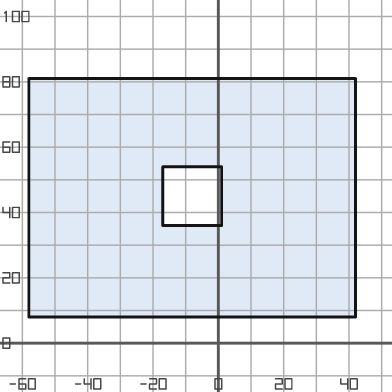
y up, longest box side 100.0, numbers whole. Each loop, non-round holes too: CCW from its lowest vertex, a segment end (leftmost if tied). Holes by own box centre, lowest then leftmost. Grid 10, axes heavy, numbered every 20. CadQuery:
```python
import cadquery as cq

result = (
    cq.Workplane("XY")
    .moveTo(-58.0, 8.0)
    .lineTo(42.0, 8.0)
    .lineTo(42.0, 81.0)
    .lineTo(-58.0, 81.0)
    .close()
    .moveTo(-17.0, 36.0)
    .lineTo(1.0, 36.0)
    .lineTo(1.0, 54.0)
    .lineTo(-17.0, 54.0)
    .close()
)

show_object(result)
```